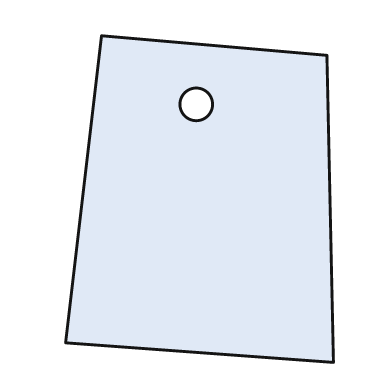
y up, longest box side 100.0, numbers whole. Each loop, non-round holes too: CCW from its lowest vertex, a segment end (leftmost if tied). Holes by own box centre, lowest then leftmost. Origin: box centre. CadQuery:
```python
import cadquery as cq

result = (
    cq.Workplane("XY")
    .moveTo(41.0, -50.0)
    .lineTo(39.0, 44.0)
    .lineTo(-30.0, 50.0)
    .lineTo(-41.0, -44.0)
    .close()
    .moveTo(-1.0, 29.0)
    .circle(5.0)
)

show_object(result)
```